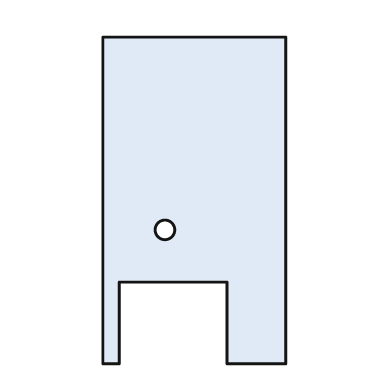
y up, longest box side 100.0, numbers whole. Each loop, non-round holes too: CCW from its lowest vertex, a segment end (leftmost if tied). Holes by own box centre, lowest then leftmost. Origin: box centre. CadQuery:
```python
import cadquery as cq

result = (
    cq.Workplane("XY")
    .moveTo(-28.0, -50.0)
    .lineTo(-23.0, -50.0)
    .lineTo(-23.0, -25.0)
    .lineTo(10.0, -25.0)
    .lineTo(10.0, -50.0)
    .lineTo(28.0, -50.0)
    .lineTo(28.0, 50.0)
    .lineTo(-28.0, 50.0)
    .close()
    .moveTo(-9.0, -9.0)
    .circle(3.0)
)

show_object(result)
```